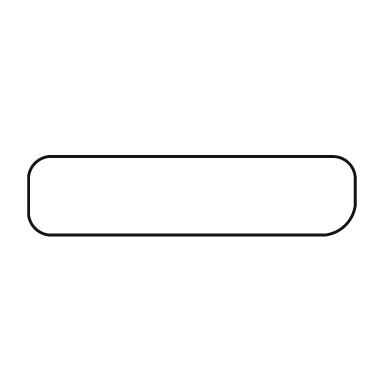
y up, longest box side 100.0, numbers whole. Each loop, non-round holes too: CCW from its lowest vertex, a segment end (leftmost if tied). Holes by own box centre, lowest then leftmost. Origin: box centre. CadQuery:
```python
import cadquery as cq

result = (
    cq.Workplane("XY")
    .moveTo(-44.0, -12.0)
    .lineTo(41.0, -12.0)
    .threePointArc((47.0, -9.0), (50.0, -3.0))
    .lineTo(50.0, 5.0)
    .threePointArc((48.0, 10.0), (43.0, 12.0))
    .lineTo(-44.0, 12.0)
    .threePointArc((-48.0, 10.0), (-50.0, 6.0))
    .lineTo(-50.0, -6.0)
    .threePointArc((-48.0, -10.0), (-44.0, -12.0))
    .close()
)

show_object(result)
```